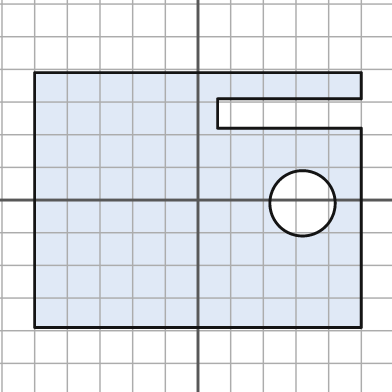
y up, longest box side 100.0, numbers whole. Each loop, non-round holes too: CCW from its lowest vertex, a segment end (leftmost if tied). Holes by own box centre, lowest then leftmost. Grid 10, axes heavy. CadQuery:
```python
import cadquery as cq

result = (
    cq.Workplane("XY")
    .moveTo(-50.0, -39.0)
    .lineTo(50.0, -39.0)
    .lineTo(50.0, 22.0)
    .lineTo(6.0, 22.0)
    .lineTo(6.0, 31.0)
    .lineTo(50.0, 31.0)
    .lineTo(50.0, 39.0)
    .lineTo(-50.0, 39.0)
    .close()
    .moveTo(32.0, -1.0)
    .circle(10.0)
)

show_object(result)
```